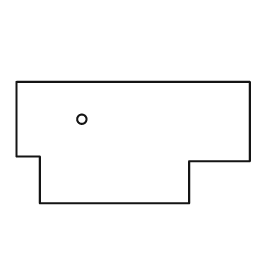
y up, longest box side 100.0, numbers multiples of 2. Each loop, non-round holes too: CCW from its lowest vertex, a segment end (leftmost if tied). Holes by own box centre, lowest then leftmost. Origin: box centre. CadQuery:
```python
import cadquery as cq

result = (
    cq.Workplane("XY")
    .moveTo(-40.0, -26.0)
    .lineTo(24.0, -26.0)
    .lineTo(24.0, -8.0)
    .lineTo(50.0, -8.0)
    .lineTo(50.0, 26.0)
    .lineTo(-50.0, 26.0)
    .lineTo(-50.0, -6.0)
    .lineTo(-40.0, -6.0)
    .close()
    .moveTo(-22.0, 10.0)
    .circle(2.0)
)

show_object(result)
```